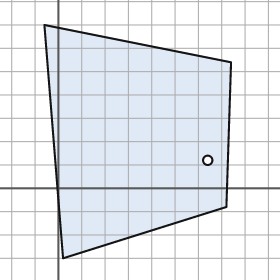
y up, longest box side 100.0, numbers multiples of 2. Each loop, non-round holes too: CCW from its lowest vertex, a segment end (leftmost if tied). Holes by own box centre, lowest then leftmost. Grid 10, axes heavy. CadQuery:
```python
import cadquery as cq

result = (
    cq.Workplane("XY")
    .moveTo(2.0, -30.0)
    .lineTo(72.0, -8.0)
    .lineTo(74.0, 54.0)
    .lineTo(-6.0, 70.0)
    .close()
    .moveTo(64.0, 12.0)
    .circle(2.0)
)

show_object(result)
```